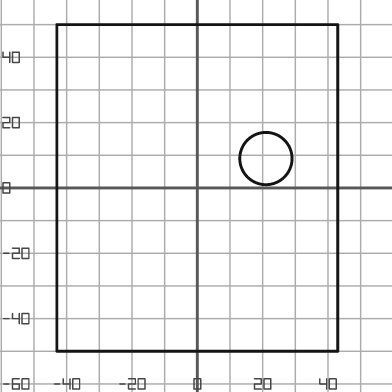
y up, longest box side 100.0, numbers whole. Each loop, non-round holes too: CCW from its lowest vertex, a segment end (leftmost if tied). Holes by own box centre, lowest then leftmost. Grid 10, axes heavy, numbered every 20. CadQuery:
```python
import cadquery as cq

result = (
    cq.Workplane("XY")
    .moveTo(-43.0, -50.0)
    .lineTo(43.0, -50.0)
    .lineTo(43.0, 50.0)
    .lineTo(-43.0, 50.0)
    .close()
    .moveTo(21.0, 9.0)
    .circle(8.0)
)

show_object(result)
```